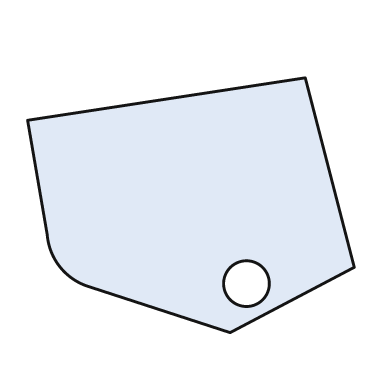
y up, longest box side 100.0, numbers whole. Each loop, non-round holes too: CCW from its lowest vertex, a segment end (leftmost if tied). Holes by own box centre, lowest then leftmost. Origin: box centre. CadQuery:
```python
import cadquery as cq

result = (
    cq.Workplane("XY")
    .moveTo(12.0, -39.0)
    .lineTo(50.0, -19.0)
    .lineTo(35.0, 39.0)
    .lineTo(-50.0, 26.0)
    .lineTo(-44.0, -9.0)
    .threePointArc((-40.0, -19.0), (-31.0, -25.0))
    .close()
    .moveTo(17.0, -24.0)
    .circle(7.0)
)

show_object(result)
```